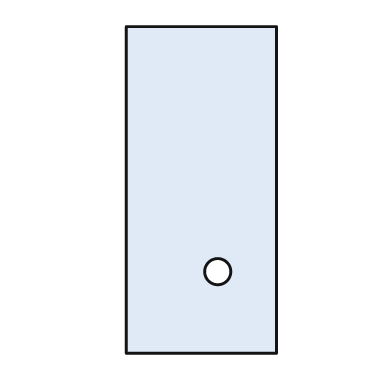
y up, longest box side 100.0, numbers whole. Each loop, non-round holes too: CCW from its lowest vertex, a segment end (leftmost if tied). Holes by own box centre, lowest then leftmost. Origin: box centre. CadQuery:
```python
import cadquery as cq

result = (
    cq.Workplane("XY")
    .moveTo(-23.0, -50.0)
    .lineTo(23.0, -50.0)
    .lineTo(23.0, 50.0)
    .lineTo(-23.0, 50.0)
    .close()
    .moveTo(5.0, -25.0)
    .circle(4.0)
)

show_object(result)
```